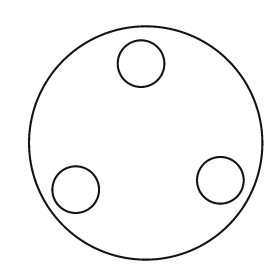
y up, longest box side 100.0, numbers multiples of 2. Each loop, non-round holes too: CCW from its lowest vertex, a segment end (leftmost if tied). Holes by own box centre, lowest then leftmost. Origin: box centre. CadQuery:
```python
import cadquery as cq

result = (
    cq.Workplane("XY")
    .moveTo(0.0, 0.0)
    .circle(50.0)
    .moveTo(-30.0, -20.0)
    .circle(10.0)
    .moveTo(32.0, -16.0)
    .circle(10.0)
    .moveTo(-2.0, 34.0)
    .circle(10.0)
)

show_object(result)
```